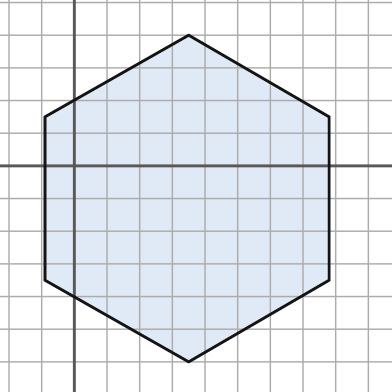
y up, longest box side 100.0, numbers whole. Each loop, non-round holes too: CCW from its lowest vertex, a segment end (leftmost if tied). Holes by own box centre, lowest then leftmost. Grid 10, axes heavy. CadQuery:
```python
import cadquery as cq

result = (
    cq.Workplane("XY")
    .moveTo(35.0, -60.0)
    .lineTo(78.0, -35.0)
    .lineTo(78.0, 15.0)
    .lineTo(35.0, 40.0)
    .lineTo(-9.0, 15.0)
    .lineTo(-9.0, -35.0)
    .close()
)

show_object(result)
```